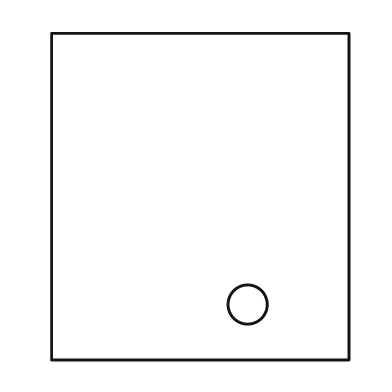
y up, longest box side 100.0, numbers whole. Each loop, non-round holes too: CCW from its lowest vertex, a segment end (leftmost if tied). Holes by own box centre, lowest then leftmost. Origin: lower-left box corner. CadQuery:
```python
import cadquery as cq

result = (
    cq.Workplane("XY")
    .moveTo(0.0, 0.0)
    .lineTo(91.0, 0.0)
    .lineTo(91.0, 100.0)
    .lineTo(0.0, 100.0)
    .close()
    .moveTo(60.0, 17.0)
    .circle(6.0)
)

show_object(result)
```